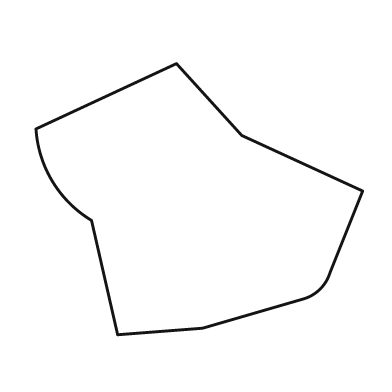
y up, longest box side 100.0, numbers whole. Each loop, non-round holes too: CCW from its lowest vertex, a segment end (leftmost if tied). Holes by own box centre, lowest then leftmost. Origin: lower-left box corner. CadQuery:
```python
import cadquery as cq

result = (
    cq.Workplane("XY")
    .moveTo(25.0, 0.0)
    .lineTo(51.0, 2.0)
    .lineTo(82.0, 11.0)
    .threePointArc((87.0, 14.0), (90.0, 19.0))
    .lineTo(100.0, 44.0)
    .lineTo(63.0, 61.0)
    .lineTo(43.0, 83.0)
    .lineTo(0.0, 63.0)
    .threePointArc((5.0, 47.0), (17.0, 35.0))
    .close()
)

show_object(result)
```